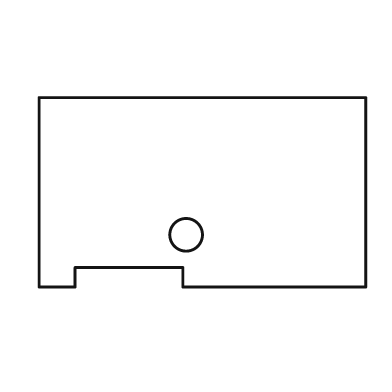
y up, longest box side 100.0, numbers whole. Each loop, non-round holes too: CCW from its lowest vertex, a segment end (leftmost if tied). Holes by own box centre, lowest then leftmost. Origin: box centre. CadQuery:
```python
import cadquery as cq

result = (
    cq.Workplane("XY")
    .moveTo(-50.0, -29.0)
    .lineTo(-39.0, -29.0)
    .lineTo(-39.0, -23.0)
    .lineTo(-6.0, -23.0)
    .lineTo(-6.0, -29.0)
    .lineTo(50.0, -29.0)
    .lineTo(50.0, 29.0)
    .lineTo(-50.0, 29.0)
    .close()
    .moveTo(-5.0, -13.0)
    .circle(5.0)
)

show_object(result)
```